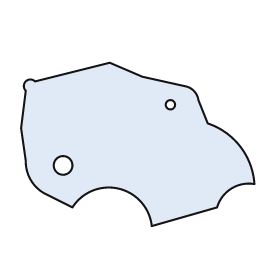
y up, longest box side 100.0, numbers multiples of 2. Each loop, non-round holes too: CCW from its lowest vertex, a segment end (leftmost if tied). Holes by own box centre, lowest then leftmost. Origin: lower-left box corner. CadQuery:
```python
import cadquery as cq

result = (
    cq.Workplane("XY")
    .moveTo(56.0, 0.0)
    .lineTo(84.0, 8.0)
    .threePointArc((90.0, 16.0), (100.0, 18.0))
    .threePointArc((94.0, 34.0), (80.0, 44.0))
    .lineTo(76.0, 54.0)
    .threePointArc((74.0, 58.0), (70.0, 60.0))
    .lineTo(52.0, 64.0)
    .lineTo(38.0, 70.0)
    .lineTo(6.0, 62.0)
    .threePointArc((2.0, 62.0), (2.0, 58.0))
    .lineTo(0.0, 42.0)
    .lineTo(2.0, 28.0)
    .threePointArc((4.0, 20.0), (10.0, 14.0))
    .lineTo(22.0, 8.0)
    .threePointArc((42.0, 16.0), (56.0, 0.0))
    .close()
    .moveTo(18.0, 26.0)
    .circle(4.0)
    .moveTo(64.0, 52.0)
    .circle(2.0)
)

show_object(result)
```